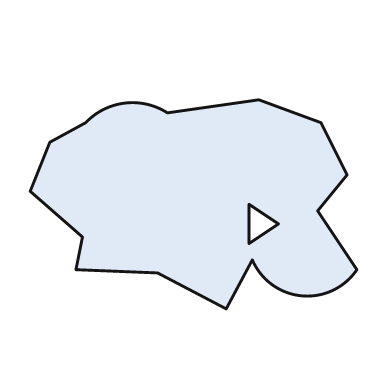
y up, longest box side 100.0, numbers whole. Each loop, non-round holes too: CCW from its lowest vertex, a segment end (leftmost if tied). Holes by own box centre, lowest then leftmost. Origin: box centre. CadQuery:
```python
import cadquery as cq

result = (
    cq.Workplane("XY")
    .moveTo(10.0, -32.0)
    .lineTo(18.0, -17.0)
    .threePointArc((33.0, -28.0), (50.0, -20.0))
    .lineTo(38.0, -2.0)
    .lineTo(47.0, 9.0)
    .lineTo(39.0, 25.0)
    .lineTo(20.0, 32.0)
    .lineTo(-8.0, 28.0)
    .threePointArc((-21.0, 31.0), (-33.0, 25.0))
    .lineTo(-44.0, 19.0)
    .lineTo(-50.0, 4.0)
    .lineTo(-34.0, -10.0)
    .lineTo(-36.0, -20.0)
    .lineTo(-11.0, -21.0)
    .close()
    .moveTo(17.0, -12.0)
    .lineTo(26.0, -6.0)
    .lineTo(17.0, 0.0)
    .close()
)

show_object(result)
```